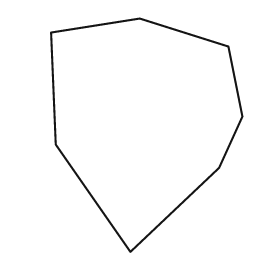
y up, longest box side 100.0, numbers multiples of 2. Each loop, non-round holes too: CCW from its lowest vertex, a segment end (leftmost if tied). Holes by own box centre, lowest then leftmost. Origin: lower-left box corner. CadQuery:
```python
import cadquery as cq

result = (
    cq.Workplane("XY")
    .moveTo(34.0, 0.0)
    .lineTo(72.0, 36.0)
    .lineTo(82.0, 58.0)
    .lineTo(76.0, 88.0)
    .lineTo(38.0, 100.0)
    .lineTo(0.0, 94.0)
    .lineTo(2.0, 46.0)
    .close()
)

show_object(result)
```